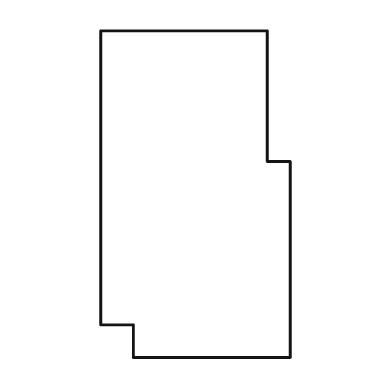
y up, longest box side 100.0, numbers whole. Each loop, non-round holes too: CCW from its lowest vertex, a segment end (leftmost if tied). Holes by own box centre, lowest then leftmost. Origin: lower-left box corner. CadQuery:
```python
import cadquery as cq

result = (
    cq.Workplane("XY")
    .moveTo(10.0, 0.0)
    .lineTo(58.0, 0.0)
    .lineTo(58.0, 60.0)
    .lineTo(51.0, 60.0)
    .lineTo(51.0, 100.0)
    .lineTo(0.0, 100.0)
    .lineTo(0.0, 10.0)
    .lineTo(10.0, 10.0)
    .close()
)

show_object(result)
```